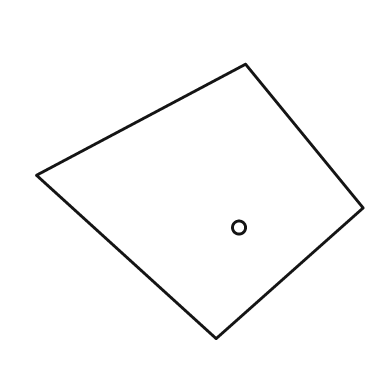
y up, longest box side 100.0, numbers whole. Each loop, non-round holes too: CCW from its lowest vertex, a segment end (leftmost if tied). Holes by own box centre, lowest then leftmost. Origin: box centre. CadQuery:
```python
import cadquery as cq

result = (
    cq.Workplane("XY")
    .moveTo(5.0, -42.0)
    .lineTo(50.0, -2.0)
    .lineTo(14.0, 42.0)
    .lineTo(-50.0, 8.0)
    .close()
    .moveTo(12.0, -8.0)
    .circle(2.0)
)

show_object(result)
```